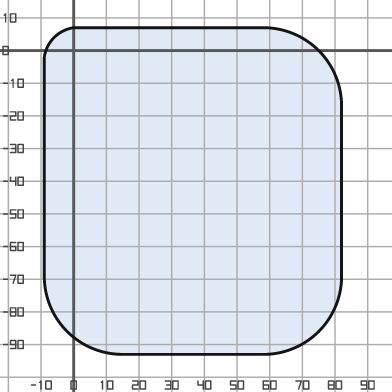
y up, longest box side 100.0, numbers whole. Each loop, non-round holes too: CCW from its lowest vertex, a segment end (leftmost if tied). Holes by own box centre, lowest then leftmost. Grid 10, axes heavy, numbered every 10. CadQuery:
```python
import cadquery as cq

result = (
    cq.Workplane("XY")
    .moveTo(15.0, -93.0)
    .lineTo(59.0, -93.0)
    .threePointArc((75.0, -86.0), (82.0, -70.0))
    .lineTo(82.0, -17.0)
    .threePointArc((75.0, 0.0), (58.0, 7.0))
    .lineTo(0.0, 7.0)
    .threePointArc((-6.0, 4.0), (-9.0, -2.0))
    .lineTo(-9.0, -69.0)
    .threePointArc((-2.0, -86.0), (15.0, -93.0))
    .close()
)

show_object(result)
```